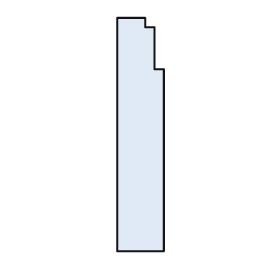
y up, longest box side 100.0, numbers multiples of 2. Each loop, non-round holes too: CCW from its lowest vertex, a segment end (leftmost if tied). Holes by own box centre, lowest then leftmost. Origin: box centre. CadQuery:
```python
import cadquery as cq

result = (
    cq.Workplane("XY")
    .moveTo(-10.0, -50.0)
    .lineTo(10.0, -50.0)
    .lineTo(10.0, 28.0)
    .lineTo(6.0, 28.0)
    .lineTo(6.0, 46.0)
    .lineTo(2.0, 46.0)
    .lineTo(2.0, 50.0)
    .lineTo(-10.0, 50.0)
    .close()
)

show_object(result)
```